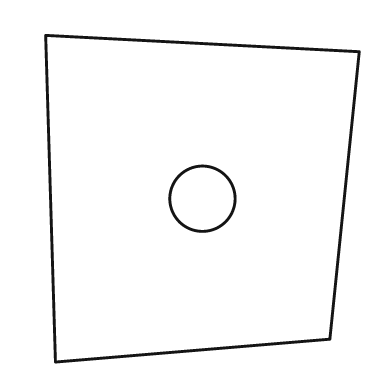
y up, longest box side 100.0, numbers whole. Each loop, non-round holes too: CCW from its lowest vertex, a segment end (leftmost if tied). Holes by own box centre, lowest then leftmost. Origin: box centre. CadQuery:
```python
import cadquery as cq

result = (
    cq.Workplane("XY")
    .moveTo(-45.0, -50.0)
    .lineTo(39.0, -43.0)
    .lineTo(48.0, 45.0)
    .lineTo(-48.0, 50.0)
    .close()
    .moveTo(0.0, 0.0)
    .circle(10.0)
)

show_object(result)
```